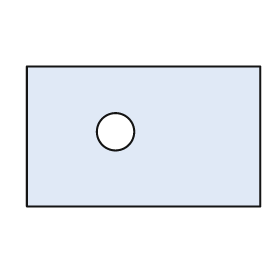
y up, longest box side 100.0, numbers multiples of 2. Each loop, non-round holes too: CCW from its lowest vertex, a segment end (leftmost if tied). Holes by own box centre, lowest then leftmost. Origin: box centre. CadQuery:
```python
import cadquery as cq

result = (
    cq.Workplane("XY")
    .moveTo(-50.0, -30.0)
    .lineTo(50.0, -30.0)
    .lineTo(50.0, 30.0)
    .lineTo(-50.0, 30.0)
    .close()
    .moveTo(-12.0, 2.0)
    .circle(8.0)
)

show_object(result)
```